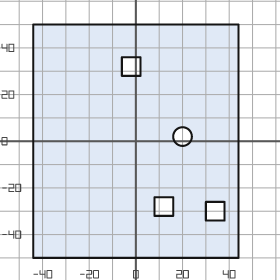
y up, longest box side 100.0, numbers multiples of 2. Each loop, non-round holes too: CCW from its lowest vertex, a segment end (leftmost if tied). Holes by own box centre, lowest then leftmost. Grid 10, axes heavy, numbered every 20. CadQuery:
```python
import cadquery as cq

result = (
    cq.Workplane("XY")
    .moveTo(-44.0, -50.0)
    .lineTo(44.0, -50.0)
    .lineTo(44.0, 50.0)
    .lineTo(-44.0, 50.0)
    .close()
    .moveTo(30.0, -34.0)
    .lineTo(38.0, -34.0)
    .lineTo(38.0, -26.0)
    .lineTo(30.0, -26.0)
    .close()
    .moveTo(8.0, -32.0)
    .lineTo(16.0, -32.0)
    .lineTo(16.0, -24.0)
    .lineTo(8.0, -24.0)
    .close()
    .moveTo(20.0, 2.0)
    .circle(4.0)
    .moveTo(-6.0, 28.0)
    .lineTo(2.0, 28.0)
    .lineTo(2.0, 36.0)
    .lineTo(-6.0, 36.0)
    .close()
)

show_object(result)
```